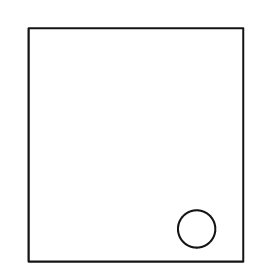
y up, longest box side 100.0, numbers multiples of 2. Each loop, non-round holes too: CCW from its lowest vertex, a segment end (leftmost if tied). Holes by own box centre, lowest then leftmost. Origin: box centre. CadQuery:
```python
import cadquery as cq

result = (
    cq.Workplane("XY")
    .moveTo(-46.0, -50.0)
    .lineTo(46.0, -50.0)
    .lineTo(46.0, 50.0)
    .lineTo(-46.0, 50.0)
    .close()
    .moveTo(26.0, -36.0)
    .circle(8.0)
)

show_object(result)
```